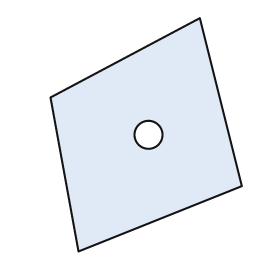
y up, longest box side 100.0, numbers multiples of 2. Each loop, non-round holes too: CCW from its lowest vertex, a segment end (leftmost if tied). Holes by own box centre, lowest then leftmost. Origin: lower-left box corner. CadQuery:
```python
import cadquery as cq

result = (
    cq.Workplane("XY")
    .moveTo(12.0, 0.0)
    .lineTo(82.0, 28.0)
    .lineTo(64.0, 100.0)
    .lineTo(0.0, 66.0)
    .close()
    .moveTo(42.0, 50.0)
    .circle(6.0)
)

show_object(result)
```